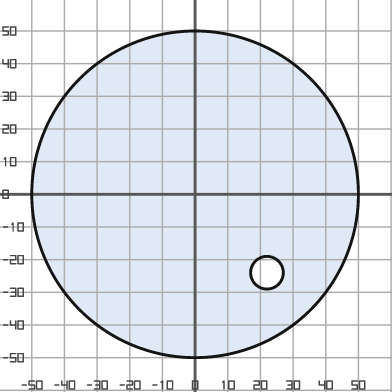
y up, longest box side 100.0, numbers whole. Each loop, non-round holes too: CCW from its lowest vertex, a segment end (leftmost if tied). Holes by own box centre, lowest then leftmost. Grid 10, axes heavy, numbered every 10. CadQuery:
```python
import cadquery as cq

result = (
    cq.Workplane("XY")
    .moveTo(0.0, 0.0)
    .circle(50.0)
    .moveTo(22.0, -24.0)
    .circle(5.0)
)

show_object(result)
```